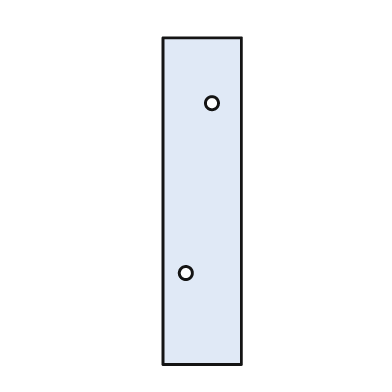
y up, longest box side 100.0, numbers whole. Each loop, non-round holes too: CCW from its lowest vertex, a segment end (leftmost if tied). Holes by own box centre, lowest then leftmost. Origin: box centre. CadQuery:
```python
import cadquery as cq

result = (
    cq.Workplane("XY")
    .moveTo(-12.0, -50.0)
    .lineTo(12.0, -50.0)
    .lineTo(12.0, 50.0)
    .lineTo(-12.0, 50.0)
    .close()
    .moveTo(-5.0, -22.0)
    .circle(2.0)
    .moveTo(3.0, 30.0)
    .circle(2.0)
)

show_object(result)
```